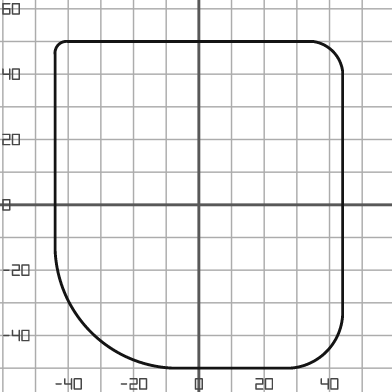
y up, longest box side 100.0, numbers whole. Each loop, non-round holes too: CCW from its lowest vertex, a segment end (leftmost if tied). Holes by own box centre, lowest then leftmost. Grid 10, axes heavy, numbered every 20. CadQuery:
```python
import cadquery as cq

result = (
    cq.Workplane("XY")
    .moveTo(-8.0, -50.0)
    .lineTo(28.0, -50.0)
    .threePointArc((39.0, -45.0), (44.0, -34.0))
    .lineTo(44.0, 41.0)
    .threePointArc((41.0, 47.0), (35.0, 50.0))
    .lineTo(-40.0, 50.0)
    .threePointArc((-43.0, 49.0), (-44.0, 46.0))
    .lineTo(-44.0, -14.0)
    .threePointArc((-33.0, -39.0), (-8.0, -50.0))
    .close()
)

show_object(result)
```